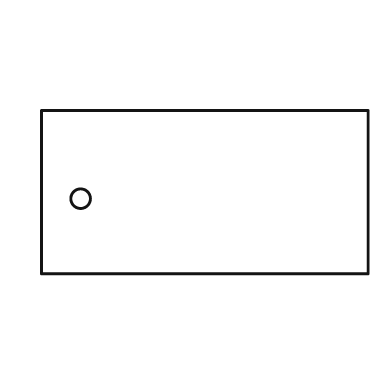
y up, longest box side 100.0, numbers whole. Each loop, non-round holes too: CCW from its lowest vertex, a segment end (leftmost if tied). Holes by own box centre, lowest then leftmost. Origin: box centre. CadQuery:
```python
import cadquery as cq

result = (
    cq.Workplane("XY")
    .moveTo(-50.0, -25.0)
    .lineTo(50.0, -25.0)
    .lineTo(50.0, 25.0)
    .lineTo(-50.0, 25.0)
    .close()
    .moveTo(-38.0, -2.0)
    .circle(3.0)
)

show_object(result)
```